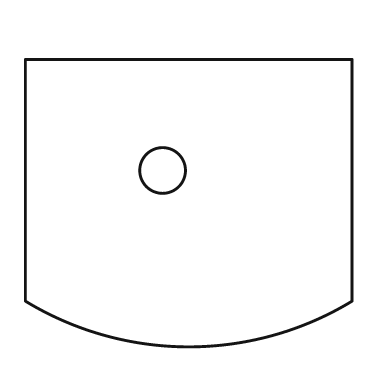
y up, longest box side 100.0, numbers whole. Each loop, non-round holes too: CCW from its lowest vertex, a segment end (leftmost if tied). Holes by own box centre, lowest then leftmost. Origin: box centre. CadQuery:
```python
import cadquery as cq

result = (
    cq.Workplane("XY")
    .moveTo(-50.0, -30.0)
    .threePointArc((0.0, -44.0), (50.0, -30.0))
    .lineTo(50.0, 44.0)
    .lineTo(-50.0, 44.0)
    .close()
    .moveTo(-8.0, 10.0)
    .circle(7.0)
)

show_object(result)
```